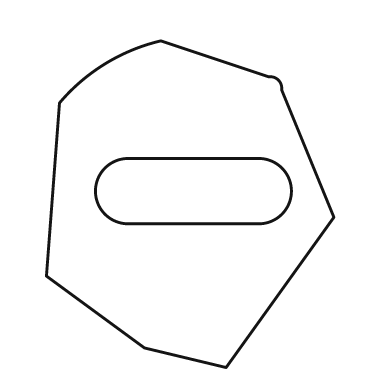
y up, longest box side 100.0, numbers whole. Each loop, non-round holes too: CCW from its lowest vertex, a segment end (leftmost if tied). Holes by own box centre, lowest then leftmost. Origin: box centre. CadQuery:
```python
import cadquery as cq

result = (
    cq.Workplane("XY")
    .moveTo(11.0, -50.0)
    .lineTo(44.0, -4.0)
    .lineTo(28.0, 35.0)
    .threePointArc((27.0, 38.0), (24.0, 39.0))
    .lineTo(-9.0, 50.0)
    .threePointArc((-26.0, 43.0), (-40.0, 31.0))
    .lineTo(-44.0, -22.0)
    .lineTo(-14.0, -44.0)
    .close()
    .moveTo(-19.0, -6.0)
    .lineTo(21.0, -6.0)
    .threePointArc((31.0, 4.0), (21.0, 14.0))
    .lineTo(-19.0, 14.0)
    .threePointArc((-29.0, 4.0), (-19.0, -6.0))
    .close()
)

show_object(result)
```